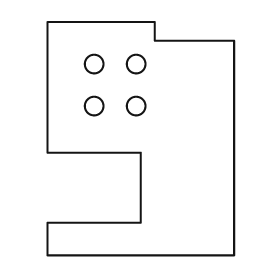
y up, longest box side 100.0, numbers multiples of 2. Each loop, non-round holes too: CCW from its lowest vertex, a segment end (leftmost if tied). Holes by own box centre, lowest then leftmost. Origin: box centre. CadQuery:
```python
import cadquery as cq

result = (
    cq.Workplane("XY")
    .moveTo(-40.0, -50.0)
    .lineTo(40.0, -50.0)
    .lineTo(40.0, 42.0)
    .lineTo(6.0, 42.0)
    .lineTo(6.0, 50.0)
    .lineTo(-40.0, 50.0)
    .lineTo(-40.0, -6.0)
    .lineTo(0.0, -6.0)
    .lineTo(0.0, -36.0)
    .lineTo(-40.0, -36.0)
    .close()
    .moveTo(-20.0, 14.0)
    .circle(4.0)
    .moveTo(-2.0, 14.0)
    .circle(4.0)
    .moveTo(-20.0, 32.0)
    .circle(4.0)
    .moveTo(-2.0, 32.0)
    .circle(4.0)
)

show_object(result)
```